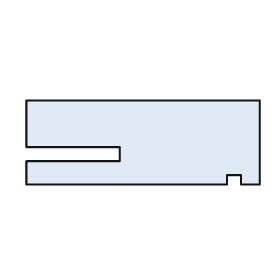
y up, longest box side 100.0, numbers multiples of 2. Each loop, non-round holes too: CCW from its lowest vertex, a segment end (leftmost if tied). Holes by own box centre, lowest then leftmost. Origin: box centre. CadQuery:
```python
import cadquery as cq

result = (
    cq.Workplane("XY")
    .moveTo(-50.0, -18.0)
    .lineTo(36.0, -18.0)
    .lineTo(36.0, -14.0)
    .lineTo(42.0, -14.0)
    .lineTo(42.0, -18.0)
    .lineTo(50.0, -18.0)
    .lineTo(50.0, 18.0)
    .lineTo(-50.0, 18.0)
    .lineTo(-50.0, -2.0)
    .lineTo(-10.0, -2.0)
    .lineTo(-10.0, -8.0)
    .lineTo(-50.0, -8.0)
    .close()
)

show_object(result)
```